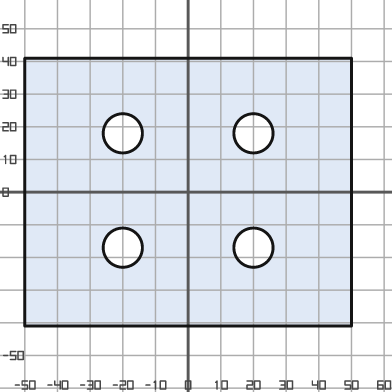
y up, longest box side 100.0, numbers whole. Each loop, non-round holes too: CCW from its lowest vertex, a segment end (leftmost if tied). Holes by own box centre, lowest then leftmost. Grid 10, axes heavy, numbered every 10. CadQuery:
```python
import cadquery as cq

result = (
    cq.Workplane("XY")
    .moveTo(-50.0, -41.0)
    .lineTo(50.0, -41.0)
    .lineTo(50.0, 41.0)
    .lineTo(-50.0, 41.0)
    .close()
    .moveTo(-20.0, -17.0)
    .circle(6.0)
    .moveTo(20.0, -17.0)
    .circle(6.0)
    .moveTo(-20.0, 18.0)
    .circle(6.0)
    .moveTo(20.0, 18.0)
    .circle(6.0)
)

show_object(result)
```